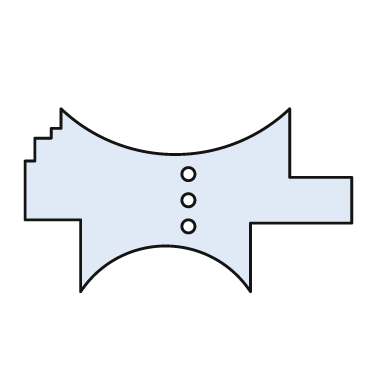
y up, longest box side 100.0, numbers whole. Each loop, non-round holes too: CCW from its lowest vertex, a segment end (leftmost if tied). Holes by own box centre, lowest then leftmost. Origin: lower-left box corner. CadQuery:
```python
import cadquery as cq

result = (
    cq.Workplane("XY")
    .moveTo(17.0, 0.0)
    .threePointArc((43.0, 14.0), (69.0, 0.0))
    .lineTo(69.0, 21.0)
    .lineTo(100.0, 21.0)
    .lineTo(100.0, 35.0)
    .lineTo(81.0, 35.0)
    .lineTo(81.0, 56.0)
    .threePointArc((46.0, 42.0), (11.0, 56.0))
    .lineTo(11.0, 50.0)
    .lineTo(8.0, 50.0)
    .lineTo(8.0, 47.0)
    .lineTo(3.0, 47.0)
    .lineTo(3.0, 40.0)
    .lineTo(0.0, 40.0)
    .lineTo(0.0, 22.0)
    .lineTo(17.0, 22.0)
    .close()
    .moveTo(50.0, 20.0)
    .circle(2.0)
    .moveTo(50.0, 28.0)
    .circle(2.0)
    .moveTo(50.0, 36.0)
    .circle(2.0)
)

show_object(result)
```